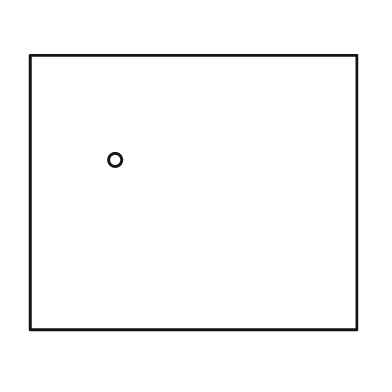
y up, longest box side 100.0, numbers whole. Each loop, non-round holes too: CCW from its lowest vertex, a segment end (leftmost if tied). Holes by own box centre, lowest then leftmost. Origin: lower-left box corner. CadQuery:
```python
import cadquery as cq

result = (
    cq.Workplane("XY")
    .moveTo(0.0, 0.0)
    .lineTo(100.0, 0.0)
    .lineTo(100.0, 84.0)
    .lineTo(0.0, 84.0)
    .close()
    .moveTo(26.0, 52.0)
    .circle(2.0)
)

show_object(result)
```